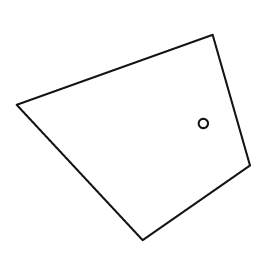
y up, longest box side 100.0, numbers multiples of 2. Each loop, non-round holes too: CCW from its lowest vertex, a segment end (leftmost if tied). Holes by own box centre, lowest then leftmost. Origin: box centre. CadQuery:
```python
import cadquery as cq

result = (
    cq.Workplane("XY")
    .moveTo(4.0, -44.0)
    .lineTo(50.0, -12.0)
    .lineTo(34.0, 44.0)
    .lineTo(-50.0, 14.0)
    .close()
    .moveTo(30.0, 6.0)
    .circle(2.0)
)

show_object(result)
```